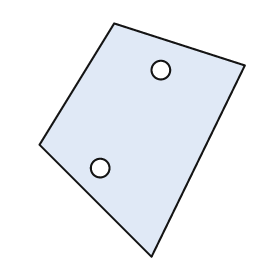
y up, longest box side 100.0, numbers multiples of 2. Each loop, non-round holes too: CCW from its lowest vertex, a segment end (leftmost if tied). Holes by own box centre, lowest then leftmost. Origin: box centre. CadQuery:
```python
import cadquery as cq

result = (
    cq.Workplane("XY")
    .moveTo(4.0, -50.0)
    .lineTo(44.0, 32.0)
    .lineTo(-12.0, 50.0)
    .lineTo(-44.0, -2.0)
    .close()
    .moveTo(-18.0, -12.0)
    .circle(4.0)
    .moveTo(8.0, 30.0)
    .circle(4.0)
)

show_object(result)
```